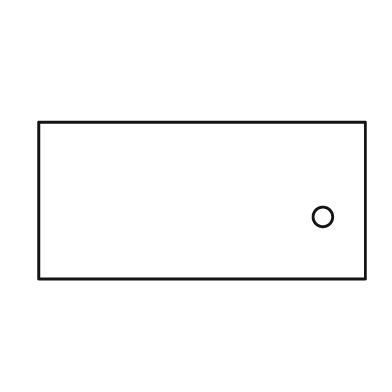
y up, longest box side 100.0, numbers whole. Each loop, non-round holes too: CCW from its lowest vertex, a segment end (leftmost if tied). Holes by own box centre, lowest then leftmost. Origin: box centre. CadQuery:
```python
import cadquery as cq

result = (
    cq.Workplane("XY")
    .moveTo(-50.0, -24.0)
    .lineTo(50.0, -24.0)
    .lineTo(50.0, 24.0)
    .lineTo(-50.0, 24.0)
    .close()
    .moveTo(37.0, -5.0)
    .circle(3.0)
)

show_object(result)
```